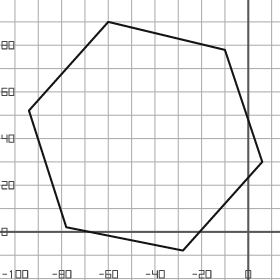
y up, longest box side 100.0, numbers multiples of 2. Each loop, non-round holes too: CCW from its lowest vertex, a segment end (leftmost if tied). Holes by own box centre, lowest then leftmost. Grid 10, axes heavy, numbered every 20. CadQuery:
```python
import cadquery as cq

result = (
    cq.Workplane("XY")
    .moveTo(-28.0, -8.0)
    .lineTo(6.0, 30.0)
    .lineTo(-10.0, 78.0)
    .lineTo(-60.0, 90.0)
    .lineTo(-94.0, 52.0)
    .lineTo(-78.0, 2.0)
    .close()
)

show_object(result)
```